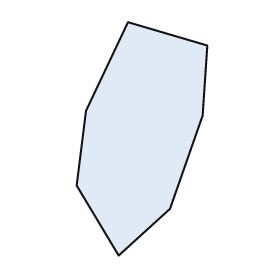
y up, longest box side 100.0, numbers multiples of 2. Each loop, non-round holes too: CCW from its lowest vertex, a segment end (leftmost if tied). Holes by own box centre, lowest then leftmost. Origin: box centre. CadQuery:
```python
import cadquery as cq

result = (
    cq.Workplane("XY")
    .moveTo(-10.0, -50.0)
    .lineTo(12.0, -30.0)
    .lineTo(26.0, 10.0)
    .lineTo(28.0, 40.0)
    .lineTo(-6.0, 50.0)
    .lineTo(-24.0, 12.0)
    .lineTo(-28.0, -20.0)
    .close()
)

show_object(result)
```